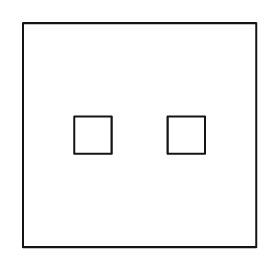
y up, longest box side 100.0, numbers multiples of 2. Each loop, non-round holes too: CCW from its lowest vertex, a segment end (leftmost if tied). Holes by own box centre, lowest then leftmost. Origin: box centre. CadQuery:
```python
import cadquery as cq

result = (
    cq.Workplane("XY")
    .moveTo(-50.0, -48.0)
    .lineTo(50.0, -48.0)
    .lineTo(50.0, 48.0)
    .lineTo(-50.0, 48.0)
    .close()
    .moveTo(-28.0, -8.0)
    .lineTo(-12.0, -8.0)
    .lineTo(-12.0, 8.0)
    .lineTo(-28.0, 8.0)
    .close()
    .moveTo(12.0, -8.0)
    .lineTo(28.0, -8.0)
    .lineTo(28.0, 8.0)
    .lineTo(12.0, 8.0)
    .close()
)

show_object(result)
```